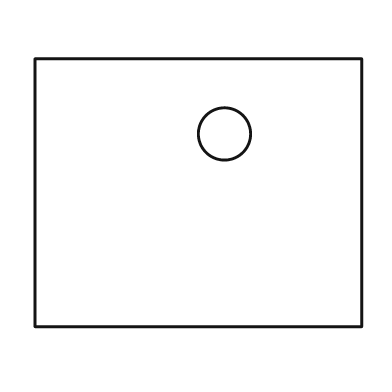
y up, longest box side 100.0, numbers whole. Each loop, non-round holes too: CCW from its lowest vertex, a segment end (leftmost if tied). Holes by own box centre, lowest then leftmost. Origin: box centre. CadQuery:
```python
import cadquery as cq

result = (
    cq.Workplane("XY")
    .moveTo(-50.0, -41.0)
    .lineTo(50.0, -41.0)
    .lineTo(50.0, 41.0)
    .lineTo(-50.0, 41.0)
    .close()
    .moveTo(8.0, 18.0)
    .circle(8.0)
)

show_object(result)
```